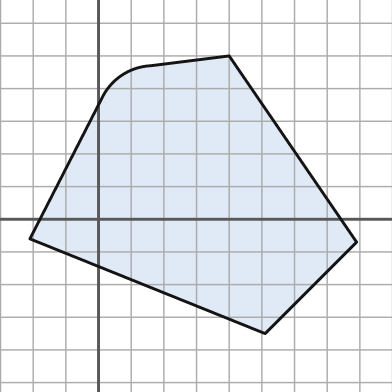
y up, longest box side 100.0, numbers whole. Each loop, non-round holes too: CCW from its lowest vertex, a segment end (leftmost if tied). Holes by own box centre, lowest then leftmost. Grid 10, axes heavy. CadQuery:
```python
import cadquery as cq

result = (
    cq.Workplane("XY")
    .moveTo(51.0, -35.0)
    .lineTo(79.0, -7.0)
    .lineTo(40.0, 50.0)
    .lineTo(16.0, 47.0)
    .threePointArc((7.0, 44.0), (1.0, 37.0))
    .lineTo(-21.0, -6.0)
    .close()
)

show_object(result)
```